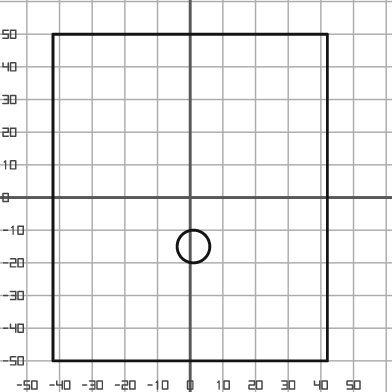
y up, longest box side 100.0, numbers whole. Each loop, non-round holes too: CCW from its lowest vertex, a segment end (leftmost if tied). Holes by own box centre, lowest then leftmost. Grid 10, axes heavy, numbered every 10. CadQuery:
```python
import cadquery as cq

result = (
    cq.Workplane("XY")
    .moveTo(-42.0, -50.0)
    .lineTo(42.0, -50.0)
    .lineTo(42.0, 50.0)
    .lineTo(-42.0, 50.0)
    .close()
    .moveTo(1.0, -15.0)
    .circle(5.0)
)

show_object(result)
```